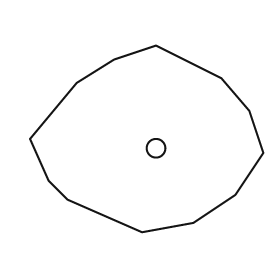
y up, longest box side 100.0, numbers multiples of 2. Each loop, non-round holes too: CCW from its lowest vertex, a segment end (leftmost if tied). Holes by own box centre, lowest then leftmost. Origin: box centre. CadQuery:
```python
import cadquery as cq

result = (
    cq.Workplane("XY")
    .moveTo(-2.0, -40.0)
    .lineTo(20.0, -36.0)
    .lineTo(38.0, -24.0)
    .lineTo(50.0, -6.0)
    .lineTo(44.0, 12.0)
    .lineTo(32.0, 26.0)
    .lineTo(4.0, 40.0)
    .lineTo(-14.0, 34.0)
    .lineTo(-30.0, 24.0)
    .lineTo(-50.0, 0.0)
    .lineTo(-42.0, -18.0)
    .lineTo(-34.0, -26.0)
    .close()
    .moveTo(4.0, -4.0)
    .circle(4.0)
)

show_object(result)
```